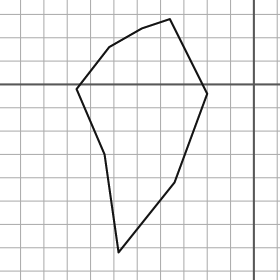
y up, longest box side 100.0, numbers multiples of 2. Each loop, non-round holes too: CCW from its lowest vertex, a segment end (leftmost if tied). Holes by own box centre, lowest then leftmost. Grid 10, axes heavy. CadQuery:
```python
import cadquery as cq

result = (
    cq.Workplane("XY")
    .moveTo(-58.0, -72.0)
    .lineTo(-34.0, -42.0)
    .lineTo(-20.0, -4.0)
    .lineTo(-36.0, 28.0)
    .lineTo(-48.0, 24.0)
    .lineTo(-62.0, 16.0)
    .lineTo(-76.0, -2.0)
    .lineTo(-64.0, -30.0)
    .close()
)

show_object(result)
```